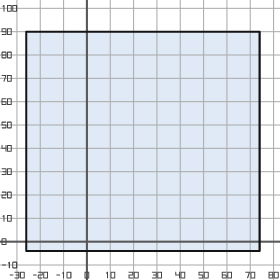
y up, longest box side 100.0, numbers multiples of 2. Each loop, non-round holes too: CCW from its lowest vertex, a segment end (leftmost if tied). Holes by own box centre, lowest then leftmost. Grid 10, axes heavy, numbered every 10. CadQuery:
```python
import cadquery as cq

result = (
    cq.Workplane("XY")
    .moveTo(-26.0, -4.0)
    .lineTo(74.0, -4.0)
    .lineTo(74.0, 90.0)
    .lineTo(-26.0, 90.0)
    .close()
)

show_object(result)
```